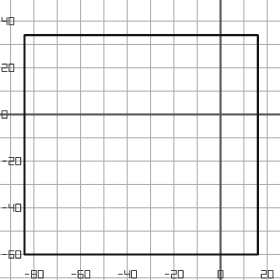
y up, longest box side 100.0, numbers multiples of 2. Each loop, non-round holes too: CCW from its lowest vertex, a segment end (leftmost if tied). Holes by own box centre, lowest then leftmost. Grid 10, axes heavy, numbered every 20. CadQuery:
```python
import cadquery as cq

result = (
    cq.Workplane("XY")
    .moveTo(-84.0, -60.0)
    .lineTo(16.0, -60.0)
    .lineTo(16.0, 34.0)
    .lineTo(-84.0, 34.0)
    .close()
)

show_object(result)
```